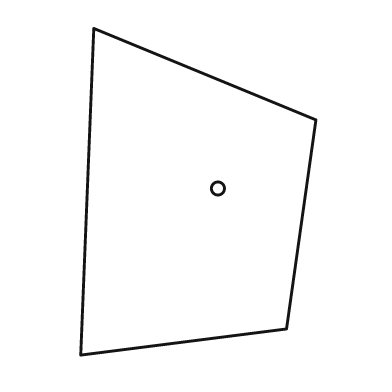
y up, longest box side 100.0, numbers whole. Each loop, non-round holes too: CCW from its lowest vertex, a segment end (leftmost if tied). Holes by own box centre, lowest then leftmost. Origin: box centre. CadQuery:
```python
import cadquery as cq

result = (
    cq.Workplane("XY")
    .moveTo(-36.0, -50.0)
    .lineTo(27.0, -42.0)
    .lineTo(36.0, 22.0)
    .lineTo(-32.0, 50.0)
    .close()
    .moveTo(6.0, 1.0)
    .circle(2.0)
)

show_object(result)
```